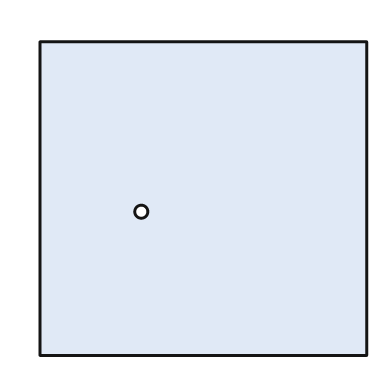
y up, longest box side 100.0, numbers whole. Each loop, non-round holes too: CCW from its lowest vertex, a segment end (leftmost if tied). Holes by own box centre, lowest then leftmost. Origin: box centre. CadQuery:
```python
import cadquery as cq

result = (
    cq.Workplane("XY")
    .moveTo(-50.0, -48.0)
    .lineTo(50.0, -48.0)
    .lineTo(50.0, 48.0)
    .lineTo(-50.0, 48.0)
    .close()
    .moveTo(-19.0, -4.0)
    .circle(2.0)
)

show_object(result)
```